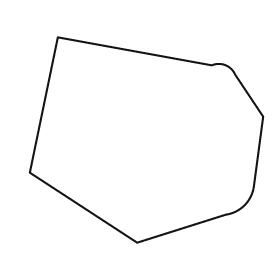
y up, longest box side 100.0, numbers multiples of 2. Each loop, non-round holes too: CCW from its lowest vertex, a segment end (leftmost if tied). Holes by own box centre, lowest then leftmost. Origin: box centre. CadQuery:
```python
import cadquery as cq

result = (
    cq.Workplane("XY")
    .moveTo(-4.0, -44.0)
    .lineTo(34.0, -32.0)
    .threePointArc((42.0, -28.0), (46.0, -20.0))
    .lineTo(50.0, 10.0)
    .lineTo(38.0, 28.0)
    .threePointArc((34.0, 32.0), (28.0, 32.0))
    .lineTo(-38.0, 44.0)
    .lineTo(-50.0, -14.0)
    .close()
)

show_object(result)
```